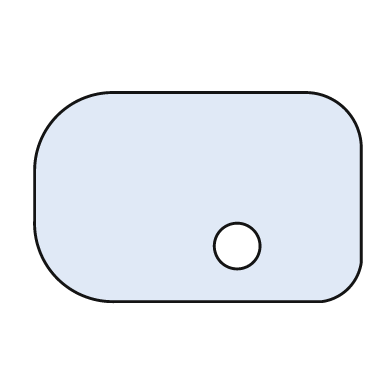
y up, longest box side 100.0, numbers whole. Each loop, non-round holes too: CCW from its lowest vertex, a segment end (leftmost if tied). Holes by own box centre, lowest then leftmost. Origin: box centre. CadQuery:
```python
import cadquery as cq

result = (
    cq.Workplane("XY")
    .moveTo(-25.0, -32.0)
    .lineTo(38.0, -32.0)
    .threePointArc((46.0, -28.0), (50.0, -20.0))
    .lineTo(50.0, 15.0)
    .threePointArc((45.0, 27.0), (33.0, 32.0))
    .lineTo(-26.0, 32.0)
    .threePointArc((-43.0, 25.0), (-50.0, 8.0))
    .lineTo(-50.0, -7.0)
    .threePointArc((-43.0, -25.0), (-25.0, -32.0))
    .close()
    .moveTo(12.0, -15.0)
    .circle(7.0)
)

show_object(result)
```